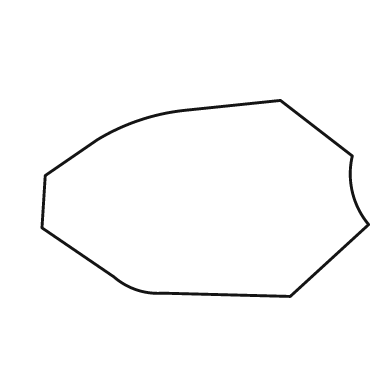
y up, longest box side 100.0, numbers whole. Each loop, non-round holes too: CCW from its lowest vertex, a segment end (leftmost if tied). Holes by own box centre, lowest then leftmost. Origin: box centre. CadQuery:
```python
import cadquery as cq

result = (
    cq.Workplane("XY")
    .moveTo(26.0, -30.0)
    .lineTo(50.0, -8.0)
    .threePointArc((45.0, 2.0), (45.0, 13.0))
    .lineTo(23.0, 30.0)
    .lineTo(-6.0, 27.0)
    .threePointArc((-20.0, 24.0), (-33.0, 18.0))
    .lineTo(-49.0, 7.0)
    .lineTo(-50.0, -9.0)
    .lineTo(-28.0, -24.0)
    .threePointArc((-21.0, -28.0), (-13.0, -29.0))
    .close()
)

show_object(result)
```